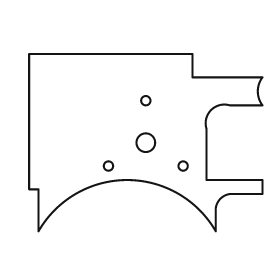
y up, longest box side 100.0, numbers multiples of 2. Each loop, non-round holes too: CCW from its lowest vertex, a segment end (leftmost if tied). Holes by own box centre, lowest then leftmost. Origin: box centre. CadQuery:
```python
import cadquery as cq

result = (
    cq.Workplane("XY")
    .moveTo(-46.0, -38.0)
    .threePointArc((-8.0, -16.0), (30.0, -38.0))
    .lineTo(30.0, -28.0)
    .threePointArc((32.0, -24.0), (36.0, -22.0))
    .lineTo(50.0, -22.0)
    .lineTo(50.0, -16.0)
    .lineTo(26.0, -16.0)
    .lineTo(26.0, 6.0)
    .threePointArc((28.0, 14.0), (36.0, 16.0))
    .lineTo(50.0, 16.0)
    .threePointArc((48.0, 22.0), (50.0, 28.0))
    .lineTo(20.0, 28.0)
    .lineTo(20.0, 38.0)
    .lineTo(-50.0, 38.0)
    .lineTo(-50.0, -20.0)
    .lineTo(-46.0, -20.0)
    .close()
    .moveTo(-16.0, -10.0)
    .circle(2.0)
    .moveTo(16.0, -10.0)
    .circle(2.0)
    .moveTo(0.0, 0.0)
    .circle(4.0)
    .moveTo(0.0, 18.0)
    .circle(2.0)
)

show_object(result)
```